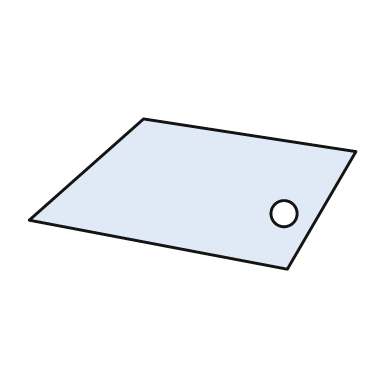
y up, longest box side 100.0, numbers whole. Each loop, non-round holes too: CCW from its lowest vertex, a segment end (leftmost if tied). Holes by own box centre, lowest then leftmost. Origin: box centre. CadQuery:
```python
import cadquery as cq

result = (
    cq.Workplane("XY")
    .moveTo(29.0, -23.0)
    .lineTo(50.0, 13.0)
    .lineTo(-15.0, 23.0)
    .lineTo(-50.0, -8.0)
    .close()
    .moveTo(28.0, -6.0)
    .circle(4.0)
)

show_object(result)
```